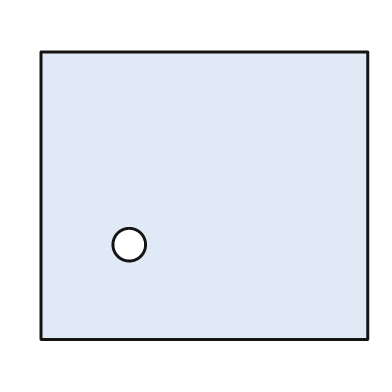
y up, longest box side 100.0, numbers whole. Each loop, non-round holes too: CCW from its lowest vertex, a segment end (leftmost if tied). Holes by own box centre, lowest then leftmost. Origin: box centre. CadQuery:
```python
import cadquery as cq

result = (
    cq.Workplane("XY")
    .moveTo(-50.0, -44.0)
    .lineTo(50.0, -44.0)
    .lineTo(50.0, 44.0)
    .lineTo(-50.0, 44.0)
    .close()
    .moveTo(-23.0, -15.0)
    .circle(5.0)
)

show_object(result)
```